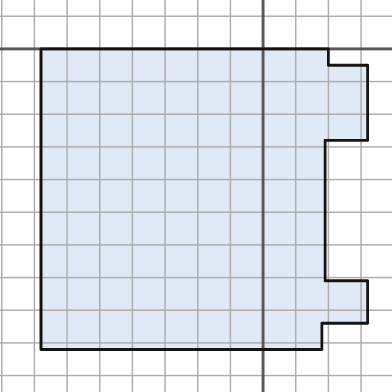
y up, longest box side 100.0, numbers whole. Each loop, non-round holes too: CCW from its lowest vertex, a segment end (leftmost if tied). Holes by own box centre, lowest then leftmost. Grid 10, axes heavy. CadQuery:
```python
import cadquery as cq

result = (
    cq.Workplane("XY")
    .moveTo(-68.0, -92.0)
    .lineTo(18.0, -92.0)
    .lineTo(18.0, -84.0)
    .lineTo(32.0, -84.0)
    .lineTo(32.0, -71.0)
    .lineTo(19.0, -71.0)
    .lineTo(19.0, -28.0)
    .lineTo(32.0, -28.0)
    .lineTo(32.0, -5.0)
    .lineTo(20.0, -5.0)
    .lineTo(20.0, 0.0)
    .lineTo(-68.0, 0.0)
    .close()
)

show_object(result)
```